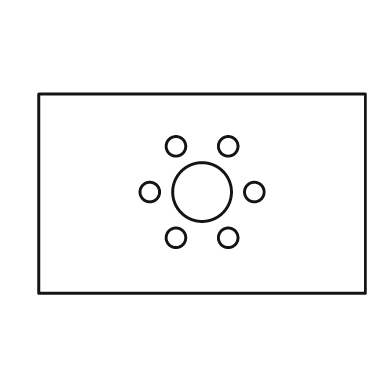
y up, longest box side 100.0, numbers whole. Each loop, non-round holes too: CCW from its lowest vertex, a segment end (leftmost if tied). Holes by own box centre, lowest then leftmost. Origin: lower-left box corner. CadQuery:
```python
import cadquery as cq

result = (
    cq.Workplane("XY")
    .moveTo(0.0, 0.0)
    .lineTo(100.0, 0.0)
    .lineTo(100.0, 61.0)
    .lineTo(0.0, 61.0)
    .close()
    .moveTo(42.0, 17.0)
    .circle(3.0)
    .moveTo(58.0, 17.0)
    .circle(3.0)
    .moveTo(34.0, 31.0)
    .circle(3.0)
    .moveTo(50.0, 31.0)
    .circle(9.0)
    .moveTo(66.0, 31.0)
    .circle(3.0)
    .moveTo(42.0, 45.0)
    .circle(3.0)
    .moveTo(58.0, 45.0)
    .circle(3.0)
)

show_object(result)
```